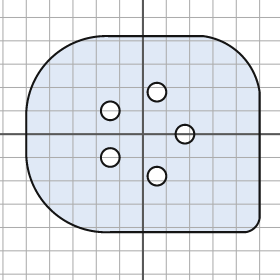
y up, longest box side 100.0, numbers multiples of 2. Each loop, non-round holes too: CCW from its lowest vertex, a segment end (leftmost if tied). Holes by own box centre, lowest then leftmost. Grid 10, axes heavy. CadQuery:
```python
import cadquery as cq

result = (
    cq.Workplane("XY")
    .moveTo(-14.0, -42.0)
    .lineTo(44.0, -42.0)
    .threePointArc((48.0, -40.0), (50.0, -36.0))
    .lineTo(50.0, 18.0)
    .threePointArc((42.0, 34.0), (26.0, 42.0))
    .lineTo(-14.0, 42.0)
    .threePointArc((-40.0, 32.0), (-50.0, 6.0))
    .lineTo(-50.0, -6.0)
    .threePointArc((-40.0, -32.0), (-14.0, -42.0))
    .close()
    .moveTo(6.0, -18.0)
    .circle(4.0)
    .moveTo(-14.0, -10.0)
    .circle(4.0)
    .moveTo(18.0, 0.0)
    .circle(4.0)
    .moveTo(-14.0, 10.0)
    .circle(4.0)
    .moveTo(6.0, 18.0)
    .circle(4.0)
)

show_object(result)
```